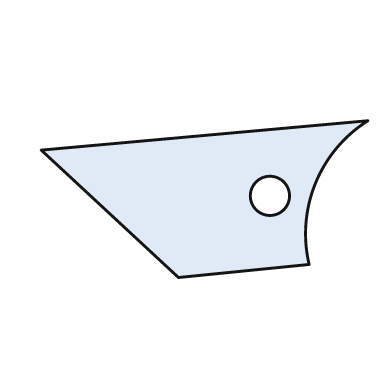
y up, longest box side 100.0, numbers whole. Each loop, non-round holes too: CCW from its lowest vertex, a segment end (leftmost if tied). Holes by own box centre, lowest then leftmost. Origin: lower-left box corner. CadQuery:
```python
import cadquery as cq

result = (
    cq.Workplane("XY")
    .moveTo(42.0, 0.0)
    .lineTo(82.0, 4.0)
    .threePointArc((84.0, 29.0), (100.0, 48.0))
    .lineTo(0.0, 39.0)
    .close()
    .moveTo(70.0, 25.0)
    .circle(6.0)
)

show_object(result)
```